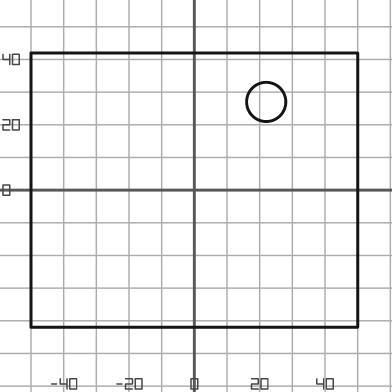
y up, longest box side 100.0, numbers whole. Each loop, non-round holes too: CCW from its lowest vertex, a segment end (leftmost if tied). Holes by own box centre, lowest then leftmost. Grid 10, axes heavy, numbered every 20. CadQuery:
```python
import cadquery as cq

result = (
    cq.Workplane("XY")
    .moveTo(-50.0, -42.0)
    .lineTo(50.0, -42.0)
    .lineTo(50.0, 42.0)
    .lineTo(-50.0, 42.0)
    .close()
    .moveTo(22.0, 27.0)
    .circle(6.0)
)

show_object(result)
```